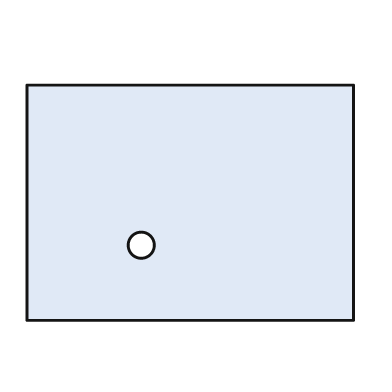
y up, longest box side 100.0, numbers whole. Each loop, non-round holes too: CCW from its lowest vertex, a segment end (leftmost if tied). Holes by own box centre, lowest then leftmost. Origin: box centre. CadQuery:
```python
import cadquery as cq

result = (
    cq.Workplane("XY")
    .moveTo(-50.0, -36.0)
    .lineTo(50.0, -36.0)
    .lineTo(50.0, 36.0)
    .lineTo(-50.0, 36.0)
    .close()
    .moveTo(-15.0, -13.0)
    .circle(4.0)
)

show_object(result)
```